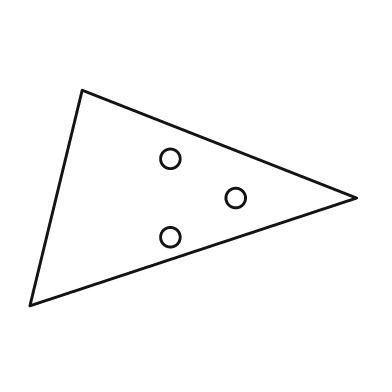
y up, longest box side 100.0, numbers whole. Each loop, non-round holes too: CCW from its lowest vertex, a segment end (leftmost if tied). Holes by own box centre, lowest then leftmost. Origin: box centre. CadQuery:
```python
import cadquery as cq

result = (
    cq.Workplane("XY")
    .moveTo(-50.0, -33.0)
    .lineTo(50.0, 0.0)
    .lineTo(-34.0, 33.0)
    .close()
    .moveTo(-7.0, -12.0)
    .circle(3.0)
    .moveTo(13.0, 0.0)
    .circle(3.0)
    .moveTo(-7.0, 12.0)
    .circle(3.0)
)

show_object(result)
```